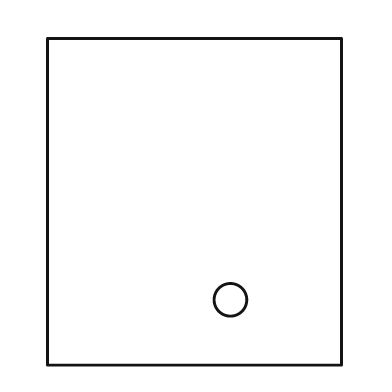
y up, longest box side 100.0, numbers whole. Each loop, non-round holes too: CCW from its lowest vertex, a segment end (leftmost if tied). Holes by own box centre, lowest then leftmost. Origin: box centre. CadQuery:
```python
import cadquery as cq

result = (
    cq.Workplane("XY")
    .moveTo(-45.0, -50.0)
    .lineTo(45.0, -50.0)
    .lineTo(45.0, 50.0)
    .lineTo(-45.0, 50.0)
    .close()
    .moveTo(11.0, -30.0)
    .circle(5.0)
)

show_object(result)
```